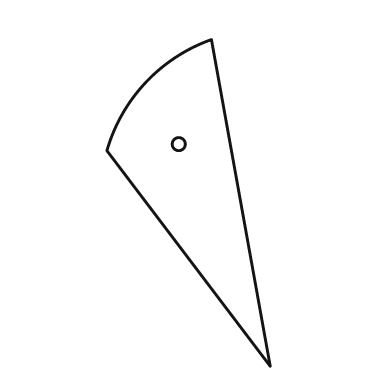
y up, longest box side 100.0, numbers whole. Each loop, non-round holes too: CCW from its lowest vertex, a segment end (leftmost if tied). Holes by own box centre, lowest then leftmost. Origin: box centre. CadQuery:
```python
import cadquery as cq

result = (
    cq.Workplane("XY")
    .moveTo(25.0, -50.0)
    .lineTo(7.0, 50.0)
    .threePointArc((-13.0, 37.0), (-25.0, 16.0))
    .close()
    .moveTo(-3.0, 18.0)
    .circle(2.0)
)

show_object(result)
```